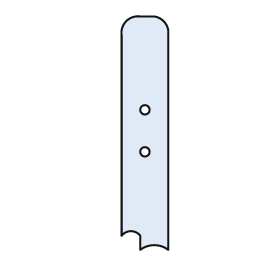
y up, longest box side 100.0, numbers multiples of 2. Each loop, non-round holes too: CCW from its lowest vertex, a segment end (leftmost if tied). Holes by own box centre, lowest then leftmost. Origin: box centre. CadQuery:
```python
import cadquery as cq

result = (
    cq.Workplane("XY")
    .moveTo(-2.0, -50.0)
    .threePointArc((4.0, -48.0), (10.0, -50.0))
    .lineTo(10.0, 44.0)
    .threePointArc((8.0, 48.0), (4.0, 50.0))
    .lineTo(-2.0, 50.0)
    .threePointArc((-8.0, 48.0), (-10.0, 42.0))
    .lineTo(-10.0, -44.0)
    .threePointArc((-6.0, -42.0), (-2.0, -44.0))
    .close()
    .moveTo(0.0, -8.0)
    .circle(2.0)
    .moveTo(0.0, 10.0)
    .circle(2.0)
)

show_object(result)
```